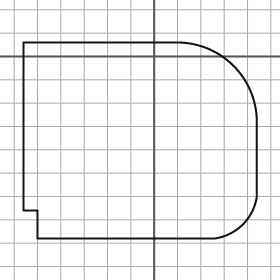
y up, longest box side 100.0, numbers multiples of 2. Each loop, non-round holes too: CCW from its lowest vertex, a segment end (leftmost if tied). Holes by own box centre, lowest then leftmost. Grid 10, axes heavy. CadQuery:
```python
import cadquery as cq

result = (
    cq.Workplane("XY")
    .moveTo(-50.0, -78.0)
    .lineTo(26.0, -78.0)
    .threePointArc((38.0, -72.0), (44.0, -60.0))
    .lineTo(44.0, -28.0)
    .threePointArc((34.0, -4.0), (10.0, 6.0))
    .lineTo(-56.0, 6.0)
    .lineTo(-56.0, -66.0)
    .lineTo(-50.0, -66.0)
    .close()
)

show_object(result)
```